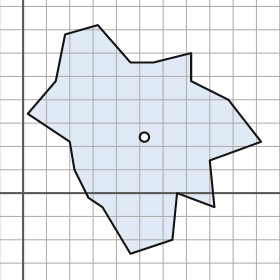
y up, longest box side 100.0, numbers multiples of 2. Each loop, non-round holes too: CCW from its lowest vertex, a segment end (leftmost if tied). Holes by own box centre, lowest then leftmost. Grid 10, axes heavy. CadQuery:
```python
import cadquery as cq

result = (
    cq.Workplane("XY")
    .moveTo(46.0, -26.0)
    .lineTo(64.0, -20.0)
    .lineTo(66.0, 0.0)
    .lineTo(82.0, -6.0)
    .lineTo(80.0, 14.0)
    .lineTo(102.0, 22.0)
    .lineTo(88.0, 40.0)
    .lineTo(72.0, 48.0)
    .lineTo(72.0, 60.0)
    .lineTo(56.0, 56.0)
    .lineTo(46.0, 56.0)
    .lineTo(32.0, 72.0)
    .lineTo(18.0, 68.0)
    .lineTo(14.0, 48.0)
    .lineTo(2.0, 34.0)
    .lineTo(20.0, 22.0)
    .lineTo(22.0, 10.0)
    .lineTo(28.0, -2.0)
    .lineTo(34.0, -6.0)
    .close()
    .moveTo(52.0, 24.0)
    .circle(2.0)
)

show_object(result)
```